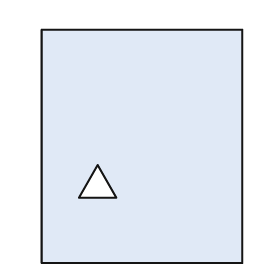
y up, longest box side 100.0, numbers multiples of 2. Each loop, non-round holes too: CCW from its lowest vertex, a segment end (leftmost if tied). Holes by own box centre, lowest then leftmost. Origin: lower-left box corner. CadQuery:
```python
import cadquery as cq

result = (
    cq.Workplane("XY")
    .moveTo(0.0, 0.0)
    .lineTo(86.0, 0.0)
    .lineTo(86.0, 100.0)
    .lineTo(0.0, 100.0)
    .close()
    .moveTo(16.0, 28.0)
    .lineTo(32.0, 28.0)
    .lineTo(24.0, 42.0)
    .close()
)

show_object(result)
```